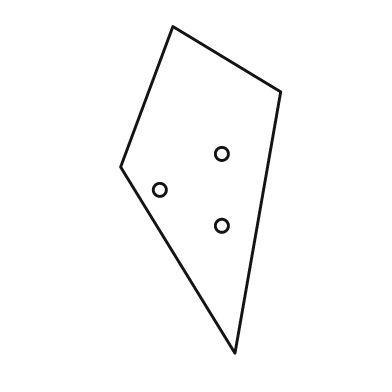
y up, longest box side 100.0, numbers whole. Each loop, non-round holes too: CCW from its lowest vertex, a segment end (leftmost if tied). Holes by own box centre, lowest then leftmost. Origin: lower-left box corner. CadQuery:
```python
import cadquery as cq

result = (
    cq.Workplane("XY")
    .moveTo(35.0, 0.0)
    .lineTo(49.0, 80.0)
    .lineTo(16.0, 100.0)
    .lineTo(0.0, 57.0)
    .close()
    .moveTo(31.0, 39.0)
    .circle(2.0)
    .moveTo(12.0, 50.0)
    .circle(2.0)
    .moveTo(31.0, 61.0)
    .circle(2.0)
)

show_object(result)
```